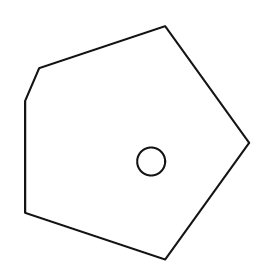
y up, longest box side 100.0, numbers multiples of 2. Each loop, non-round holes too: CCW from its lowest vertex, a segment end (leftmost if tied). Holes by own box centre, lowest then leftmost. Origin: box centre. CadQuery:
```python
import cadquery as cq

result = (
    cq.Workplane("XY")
    .moveTo(12.0, -50.0)
    .lineTo(48.0, 0.0)
    .lineTo(12.0, 50.0)
    .lineTo(-42.0, 32.0)
    .lineTo(-48.0, 18.0)
    .lineTo(-48.0, -30.0)
    .close()
    .moveTo(6.0, -8.0)
    .circle(6.0)
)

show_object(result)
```